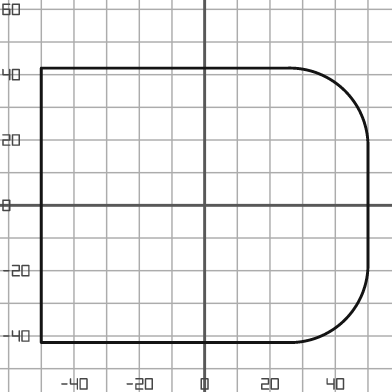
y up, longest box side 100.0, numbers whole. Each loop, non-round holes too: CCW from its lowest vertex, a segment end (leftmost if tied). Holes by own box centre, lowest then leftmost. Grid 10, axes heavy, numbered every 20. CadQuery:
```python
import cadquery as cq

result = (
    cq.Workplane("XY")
    .moveTo(-50.0, -42.0)
    .lineTo(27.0, -42.0)
    .threePointArc((43.0, -35.0), (50.0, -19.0))
    .lineTo(50.0, 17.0)
    .threePointArc((43.0, 35.0), (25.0, 42.0))
    .lineTo(-50.0, 42.0)
    .close()
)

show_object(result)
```